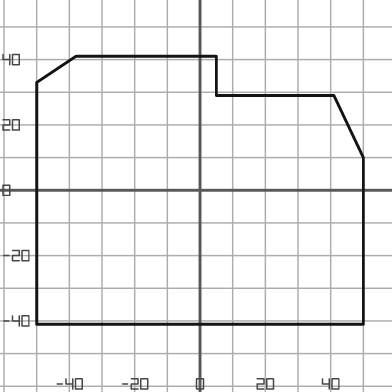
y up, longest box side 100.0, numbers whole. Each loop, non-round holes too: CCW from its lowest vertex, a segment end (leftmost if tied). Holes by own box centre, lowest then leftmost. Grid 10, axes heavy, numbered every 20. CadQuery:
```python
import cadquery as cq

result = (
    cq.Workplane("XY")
    .moveTo(-50.0, -41.0)
    .lineTo(50.0, -41.0)
    .lineTo(50.0, 10.0)
    .lineTo(41.0, 29.0)
    .lineTo(5.0, 29.0)
    .lineTo(5.0, 41.0)
    .lineTo(-38.0, 41.0)
    .lineTo(-50.0, 33.0)
    .close()
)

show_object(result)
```